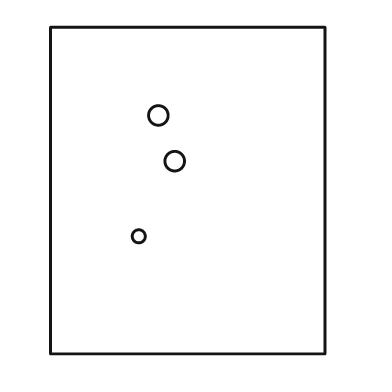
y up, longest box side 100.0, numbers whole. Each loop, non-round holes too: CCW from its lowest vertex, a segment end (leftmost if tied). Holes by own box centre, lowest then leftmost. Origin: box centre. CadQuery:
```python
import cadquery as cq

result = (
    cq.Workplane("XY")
    .moveTo(-42.0, -50.0)
    .lineTo(42.0, -50.0)
    .lineTo(42.0, 50.0)
    .lineTo(-42.0, 50.0)
    .close()
    .moveTo(-15.0, -14.0)
    .circle(2.0)
    .moveTo(-4.0, 9.0)
    .circle(3.0)
    .moveTo(-9.0, 23.0)
    .circle(3.0)
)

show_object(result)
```